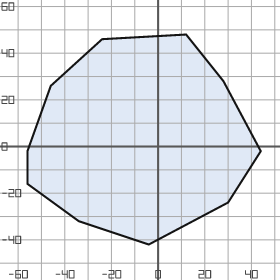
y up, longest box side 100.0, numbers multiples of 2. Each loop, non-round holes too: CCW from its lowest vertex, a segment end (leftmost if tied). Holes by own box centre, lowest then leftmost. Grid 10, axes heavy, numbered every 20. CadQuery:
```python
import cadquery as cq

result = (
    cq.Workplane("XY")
    .moveTo(-4.0, -42.0)
    .lineTo(30.0, -24.0)
    .lineTo(44.0, -2.0)
    .lineTo(28.0, 28.0)
    .lineTo(12.0, 48.0)
    .lineTo(-24.0, 46.0)
    .lineTo(-46.0, 26.0)
    .lineTo(-56.0, -2.0)
    .lineTo(-56.0, -16.0)
    .lineTo(-34.0, -32.0)
    .close()
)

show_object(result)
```